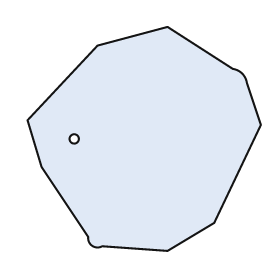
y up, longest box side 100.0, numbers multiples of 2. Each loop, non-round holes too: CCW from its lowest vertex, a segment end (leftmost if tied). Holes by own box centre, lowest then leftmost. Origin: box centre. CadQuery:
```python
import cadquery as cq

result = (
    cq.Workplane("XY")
    .moveTo(10.0, -48.0)
    .lineTo(30.0, -36.0)
    .lineTo(50.0, 6.0)
    .lineTo(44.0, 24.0)
    .threePointArc((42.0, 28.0), (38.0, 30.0))
    .lineTo(10.0, 48.0)
    .lineTo(-20.0, 40.0)
    .lineTo(-50.0, 8.0)
    .lineTo(-44.0, -12.0)
    .lineTo(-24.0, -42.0)
    .threePointArc((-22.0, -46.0), (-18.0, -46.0))
    .close()
    .moveTo(-30.0, 0.0)
    .circle(2.0)
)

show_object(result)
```